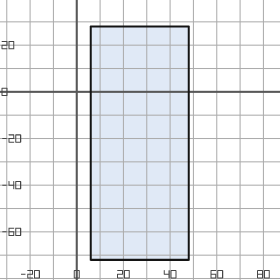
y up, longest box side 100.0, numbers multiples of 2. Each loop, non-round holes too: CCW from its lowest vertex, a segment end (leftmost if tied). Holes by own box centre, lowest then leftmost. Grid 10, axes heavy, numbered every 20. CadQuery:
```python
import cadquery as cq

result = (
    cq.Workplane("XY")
    .moveTo(6.0, -72.0)
    .lineTo(48.0, -72.0)
    .lineTo(48.0, 28.0)
    .lineTo(6.0, 28.0)
    .close()
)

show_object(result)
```